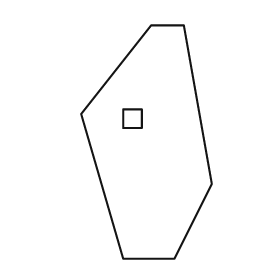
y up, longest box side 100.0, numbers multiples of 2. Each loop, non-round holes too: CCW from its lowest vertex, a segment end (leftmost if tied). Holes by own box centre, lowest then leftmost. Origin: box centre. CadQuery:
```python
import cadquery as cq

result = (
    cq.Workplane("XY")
    .moveTo(-10.0, -50.0)
    .lineTo(12.0, -50.0)
    .lineTo(28.0, -18.0)
    .lineTo(16.0, 50.0)
    .lineTo(2.0, 50.0)
    .lineTo(-28.0, 12.0)
    .close()
    .moveTo(-10.0, 6.0)
    .lineTo(-2.0, 6.0)
    .lineTo(-2.0, 14.0)
    .lineTo(-10.0, 14.0)
    .close()
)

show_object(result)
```